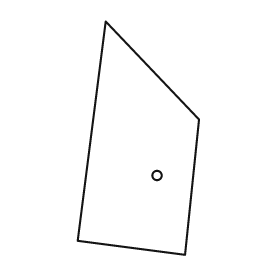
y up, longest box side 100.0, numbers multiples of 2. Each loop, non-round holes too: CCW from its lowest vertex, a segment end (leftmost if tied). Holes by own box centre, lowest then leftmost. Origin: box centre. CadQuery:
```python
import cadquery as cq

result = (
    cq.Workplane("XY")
    .moveTo(20.0, -50.0)
    .lineTo(26.0, 8.0)
    .lineTo(-14.0, 50.0)
    .lineTo(-26.0, -44.0)
    .close()
    .moveTo(8.0, -16.0)
    .circle(2.0)
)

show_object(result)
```